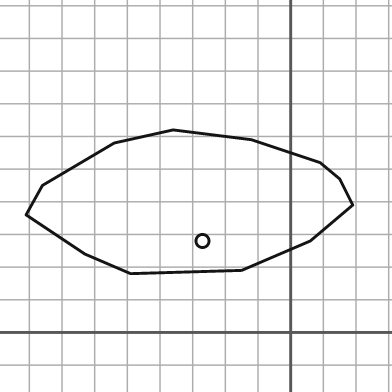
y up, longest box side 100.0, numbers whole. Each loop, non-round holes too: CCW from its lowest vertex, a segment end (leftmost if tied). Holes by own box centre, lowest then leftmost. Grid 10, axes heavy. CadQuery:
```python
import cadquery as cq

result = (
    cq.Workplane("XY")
    .moveTo(-49.0, 18.0)
    .lineTo(-15.0, 19.0)
    .lineTo(6.0, 28.0)
    .lineTo(19.0, 39.0)
    .lineTo(15.0, 47.0)
    .lineTo(9.0, 52.0)
    .lineTo(-12.0, 59.0)
    .lineTo(-36.0, 62.0)
    .lineTo(-54.0, 58.0)
    .lineTo(-76.0, 45.0)
    .lineTo(-81.0, 36.0)
    .lineTo(-63.0, 24.0)
    .close()
    .moveTo(-27.0, 28.0)
    .circle(2.0)
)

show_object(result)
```